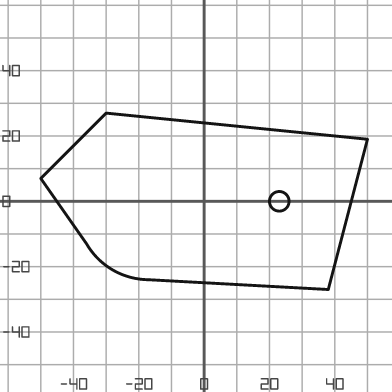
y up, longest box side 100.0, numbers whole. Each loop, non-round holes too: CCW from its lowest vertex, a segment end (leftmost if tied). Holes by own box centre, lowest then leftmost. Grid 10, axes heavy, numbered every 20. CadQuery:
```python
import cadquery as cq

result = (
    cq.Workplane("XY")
    .moveTo(38.0, -27.0)
    .lineTo(50.0, 19.0)
    .lineTo(-30.0, 27.0)
    .lineTo(-50.0, 7.0)
    .lineTo(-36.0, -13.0)
    .threePointArc((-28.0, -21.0), (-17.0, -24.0))
    .close()
    .moveTo(23.0, 0.0)
    .circle(3.0)
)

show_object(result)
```